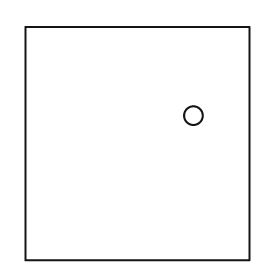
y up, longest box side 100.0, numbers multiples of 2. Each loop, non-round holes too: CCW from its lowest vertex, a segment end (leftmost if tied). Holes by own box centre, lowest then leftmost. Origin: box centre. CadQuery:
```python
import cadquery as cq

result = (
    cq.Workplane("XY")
    .moveTo(-48.0, -50.0)
    .lineTo(48.0, -50.0)
    .lineTo(48.0, 50.0)
    .lineTo(-48.0, 50.0)
    .close()
    .moveTo(24.0, 12.0)
    .circle(4.0)
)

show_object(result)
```